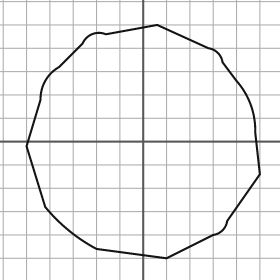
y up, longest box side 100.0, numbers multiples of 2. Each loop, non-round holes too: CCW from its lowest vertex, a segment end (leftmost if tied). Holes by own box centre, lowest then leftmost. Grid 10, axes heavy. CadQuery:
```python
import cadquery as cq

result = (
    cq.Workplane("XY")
    .moveTo(10.0, -50.0)
    .lineTo(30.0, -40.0)
    .threePointArc((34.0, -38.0), (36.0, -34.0))
    .lineTo(50.0, -14.0)
    .lineTo(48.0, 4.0)
    .threePointArc((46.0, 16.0), (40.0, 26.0))
    .lineTo(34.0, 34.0)
    .threePointArc((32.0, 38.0), (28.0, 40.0))
    .lineTo(6.0, 50.0)
    .lineTo(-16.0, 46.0)
    .threePointArc((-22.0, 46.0), (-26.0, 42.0))
    .lineTo(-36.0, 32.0)
    .threePointArc((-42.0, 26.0), (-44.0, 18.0))
    .lineTo(-50.0, -2.0)
    .lineTo(-42.0, -28.0)
    .threePointArc((-32.0, -38.0), (-20.0, -46.0))
    .close()
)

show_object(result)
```